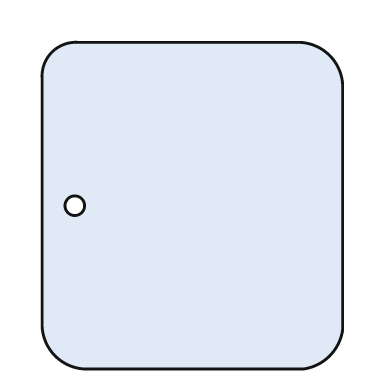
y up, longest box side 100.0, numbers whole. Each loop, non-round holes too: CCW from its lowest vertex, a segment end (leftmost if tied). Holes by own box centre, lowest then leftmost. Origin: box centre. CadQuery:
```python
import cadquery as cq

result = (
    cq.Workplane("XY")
    .moveTo(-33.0, -50.0)
    .lineTo(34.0, -50.0)
    .threePointArc((42.0, -46.0), (46.0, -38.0))
    .lineTo(46.0, 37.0)
    .threePointArc((42.0, 46.0), (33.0, 50.0))
    .lineTo(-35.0, 50.0)
    .threePointArc((-43.0, 47.0), (-46.0, 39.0))
    .lineTo(-46.0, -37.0)
    .threePointArc((-42.0, -46.0), (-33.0, -50.0))
    .close()
    .moveTo(-36.0, 0.0)
    .circle(3.0)
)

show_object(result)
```